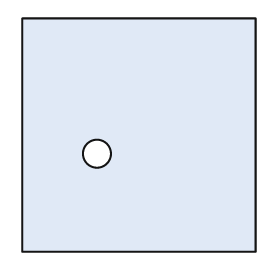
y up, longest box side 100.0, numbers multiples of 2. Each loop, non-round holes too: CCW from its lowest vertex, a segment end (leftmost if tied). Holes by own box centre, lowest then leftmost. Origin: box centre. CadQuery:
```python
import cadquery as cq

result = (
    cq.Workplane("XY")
    .moveTo(-50.0, -50.0)
    .lineTo(50.0, -50.0)
    .lineTo(50.0, 50.0)
    .lineTo(-50.0, 50.0)
    .close()
    .moveTo(-18.0, -8.0)
    .circle(6.0)
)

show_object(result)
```